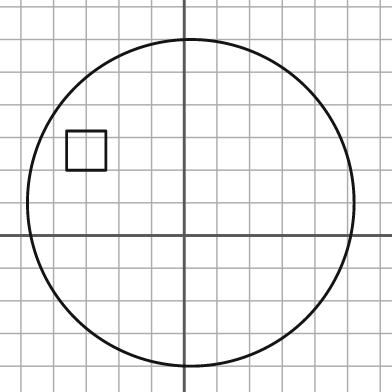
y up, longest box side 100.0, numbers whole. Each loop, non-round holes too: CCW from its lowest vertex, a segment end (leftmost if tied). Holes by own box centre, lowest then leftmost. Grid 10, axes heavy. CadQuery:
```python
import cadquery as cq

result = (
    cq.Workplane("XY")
    .moveTo(2.0, 10.0)
    .circle(50.0)
    .moveTo(-36.0, 20.0)
    .lineTo(-24.0, 20.0)
    .lineTo(-24.0, 32.0)
    .lineTo(-36.0, 32.0)
    .close()
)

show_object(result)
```